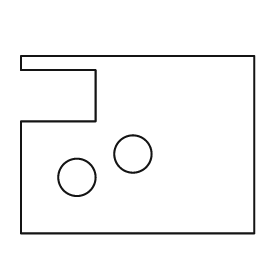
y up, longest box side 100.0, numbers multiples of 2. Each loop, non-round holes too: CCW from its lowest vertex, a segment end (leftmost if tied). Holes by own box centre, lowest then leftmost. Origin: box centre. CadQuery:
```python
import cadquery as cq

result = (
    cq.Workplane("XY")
    .moveTo(-50.0, -38.0)
    .lineTo(50.0, -38.0)
    .lineTo(50.0, 38.0)
    .lineTo(-50.0, 38.0)
    .lineTo(-50.0, 32.0)
    .lineTo(-18.0, 32.0)
    .lineTo(-18.0, 10.0)
    .lineTo(-50.0, 10.0)
    .close()
    .moveTo(-26.0, -14.0)
    .circle(8.0)
    .moveTo(-2.0, -4.0)
    .circle(8.0)
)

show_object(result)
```